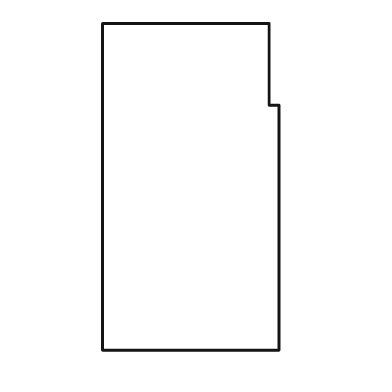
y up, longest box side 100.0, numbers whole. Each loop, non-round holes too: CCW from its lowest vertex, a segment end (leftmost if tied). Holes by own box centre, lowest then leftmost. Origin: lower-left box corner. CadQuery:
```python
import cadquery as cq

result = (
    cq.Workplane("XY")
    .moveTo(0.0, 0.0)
    .lineTo(54.0, 0.0)
    .lineTo(54.0, 75.0)
    .lineTo(51.0, 75.0)
    .lineTo(51.0, 100.0)
    .lineTo(0.0, 100.0)
    .close()
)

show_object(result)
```